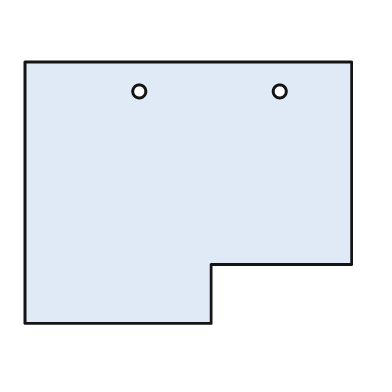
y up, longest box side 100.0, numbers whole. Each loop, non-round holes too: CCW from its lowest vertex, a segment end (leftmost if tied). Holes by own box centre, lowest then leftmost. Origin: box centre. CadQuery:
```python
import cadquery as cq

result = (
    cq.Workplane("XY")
    .moveTo(-50.0, -40.0)
    .lineTo(7.0, -40.0)
    .lineTo(7.0, -22.0)
    .lineTo(50.0, -22.0)
    .lineTo(50.0, 40.0)
    .lineTo(-50.0, 40.0)
    .close()
    .moveTo(-15.0, 31.0)
    .circle(2.0)
    .moveTo(28.0, 31.0)
    .circle(2.0)
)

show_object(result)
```